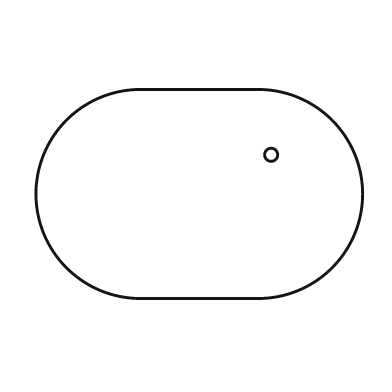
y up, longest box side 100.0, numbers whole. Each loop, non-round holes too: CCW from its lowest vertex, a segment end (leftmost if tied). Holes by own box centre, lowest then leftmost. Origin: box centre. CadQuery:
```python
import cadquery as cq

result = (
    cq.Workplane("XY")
    .moveTo(-18.0, -32.0)
    .lineTo(18.0, -32.0)
    .threePointArc((50.0, 0.0), (18.0, 32.0))
    .lineTo(-18.0, 32.0)
    .threePointArc((-50.0, 0.0), (-18.0, -32.0))
    .close()
    .moveTo(22.0, 12.0)
    .circle(2.0)
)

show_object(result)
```